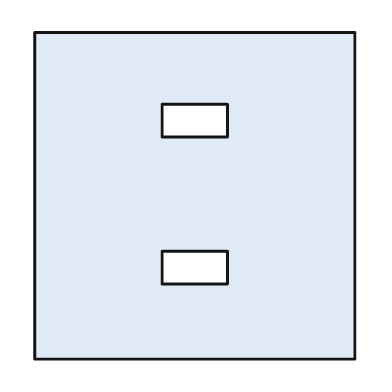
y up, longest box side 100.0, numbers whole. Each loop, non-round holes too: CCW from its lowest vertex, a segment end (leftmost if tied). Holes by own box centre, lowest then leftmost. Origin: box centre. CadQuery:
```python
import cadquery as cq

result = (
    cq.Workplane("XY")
    .moveTo(-49.0, -50.0)
    .lineTo(49.0, -50.0)
    .lineTo(49.0, 50.0)
    .lineTo(-49.0, 50.0)
    .close()
    .moveTo(-10.0, -27.0)
    .lineTo(10.0, -27.0)
    .lineTo(10.0, -17.0)
    .lineTo(-10.0, -17.0)
    .close()
    .moveTo(-10.0, 18.0)
    .lineTo(10.0, 18.0)
    .lineTo(10.0, 28.0)
    .lineTo(-10.0, 28.0)
    .close()
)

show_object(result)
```